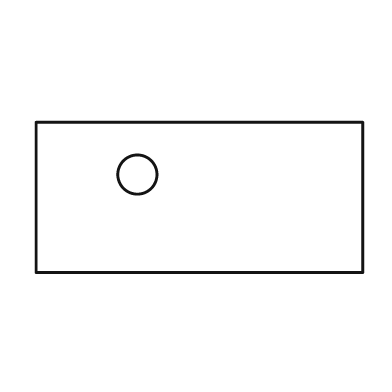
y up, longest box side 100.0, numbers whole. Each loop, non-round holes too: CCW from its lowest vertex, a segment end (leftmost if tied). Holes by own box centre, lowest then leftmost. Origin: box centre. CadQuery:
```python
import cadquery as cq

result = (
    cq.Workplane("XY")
    .moveTo(-50.0, -23.0)
    .lineTo(50.0, -23.0)
    .lineTo(50.0, 23.0)
    .lineTo(-50.0, 23.0)
    .close()
    .moveTo(-19.0, 7.0)
    .circle(6.0)
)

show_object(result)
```